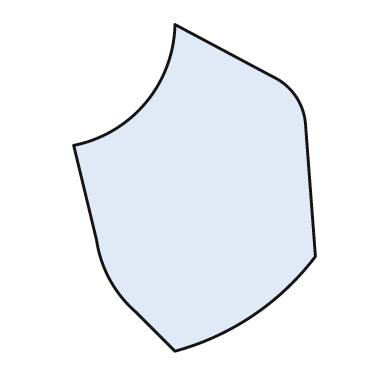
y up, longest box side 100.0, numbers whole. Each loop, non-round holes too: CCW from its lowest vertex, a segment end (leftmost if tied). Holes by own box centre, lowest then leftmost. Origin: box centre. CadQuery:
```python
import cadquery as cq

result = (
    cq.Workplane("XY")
    .moveTo(-6.0, -50.0)
    .threePointArc((18.0, -39.0), (37.0, -21.0))
    .lineTo(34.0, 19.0)
    .threePointArc((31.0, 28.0), (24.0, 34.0))
    .lineTo(-6.0, 50.0)
    .threePointArc((-15.0, 26.0), (-37.0, 13.0))
    .lineTo(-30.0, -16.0)
    .threePointArc((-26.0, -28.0), (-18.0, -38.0))
    .close()
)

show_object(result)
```